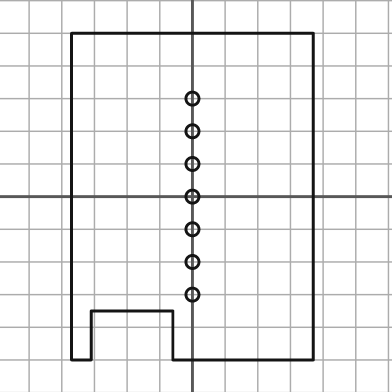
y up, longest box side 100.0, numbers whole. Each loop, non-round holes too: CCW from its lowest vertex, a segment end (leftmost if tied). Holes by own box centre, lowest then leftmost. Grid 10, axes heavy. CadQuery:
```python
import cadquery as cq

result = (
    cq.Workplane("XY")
    .moveTo(-37.0, -50.0)
    .lineTo(-31.0, -50.0)
    .lineTo(-31.0, -35.0)
    .lineTo(-6.0, -35.0)
    .lineTo(-6.0, -50.0)
    .lineTo(37.0, -50.0)
    .lineTo(37.0, 50.0)
    .lineTo(-37.0, 50.0)
    .close()
    .moveTo(0.0, -30.0)
    .circle(2.0)
    .moveTo(0.0, -20.0)
    .circle(2.0)
    .moveTo(0.0, -10.0)
    .circle(2.0)
    .moveTo(0.0, 0.0)
    .circle(2.0)
    .moveTo(0.0, 10.0)
    .circle(2.0)
    .moveTo(0.0, 20.0)
    .circle(2.0)
    .moveTo(0.0, 30.0)
    .circle(2.0)
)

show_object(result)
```